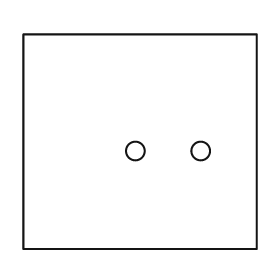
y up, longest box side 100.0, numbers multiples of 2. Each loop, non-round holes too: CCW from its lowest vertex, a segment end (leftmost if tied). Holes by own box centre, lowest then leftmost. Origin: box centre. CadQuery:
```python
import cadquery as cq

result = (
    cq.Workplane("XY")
    .moveTo(-50.0, -46.0)
    .lineTo(50.0, -46.0)
    .lineTo(50.0, 46.0)
    .lineTo(-50.0, 46.0)
    .close()
    .moveTo(-2.0, -4.0)
    .circle(4.0)
    .moveTo(26.0, -4.0)
    .circle(4.0)
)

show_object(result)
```